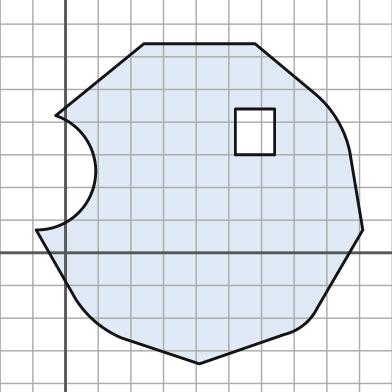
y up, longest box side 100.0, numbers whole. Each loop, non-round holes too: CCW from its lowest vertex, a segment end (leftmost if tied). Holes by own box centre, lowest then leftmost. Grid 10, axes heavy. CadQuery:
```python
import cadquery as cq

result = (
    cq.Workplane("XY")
    .moveTo(41.0, -34.0)
    .lineTo(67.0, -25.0)
    .threePointArc((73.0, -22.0), (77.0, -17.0))
    .lineTo(91.0, 7.0)
    .lineTo(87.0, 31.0)
    .threePointArc((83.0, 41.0), (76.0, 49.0))
    .lineTo(58.0, 64.0)
    .lineTo(24.0, 64.0)
    .lineTo(-3.0, 42.0)
    .threePointArc((9.0, 22.0), (-9.0, 7.0))
    .lineTo(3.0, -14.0)
    .threePointArc((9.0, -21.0), (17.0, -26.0))
    .close()
    .moveTo(52.0, 30.0)
    .lineTo(64.0, 30.0)
    .lineTo(64.0, 44.0)
    .lineTo(52.0, 44.0)
    .close()
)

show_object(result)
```